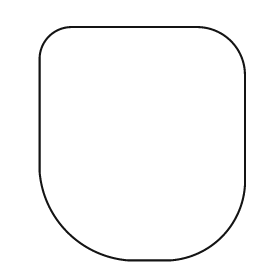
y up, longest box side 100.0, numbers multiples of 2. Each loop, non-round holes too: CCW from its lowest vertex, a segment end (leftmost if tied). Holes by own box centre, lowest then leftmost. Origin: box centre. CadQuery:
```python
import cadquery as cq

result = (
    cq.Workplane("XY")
    .moveTo(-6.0, -50.0)
    .lineTo(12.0, -50.0)
    .threePointArc((34.0, -40.0), (44.0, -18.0))
    .lineTo(44.0, 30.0)
    .threePointArc((38.0, 44.0), (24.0, 50.0))
    .lineTo(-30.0, 50.0)
    .threePointArc((-40.0, 46.0), (-44.0, 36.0))
    .lineTo(-44.0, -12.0)
    .threePointArc((-32.0, -38.0), (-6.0, -50.0))
    .close()
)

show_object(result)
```